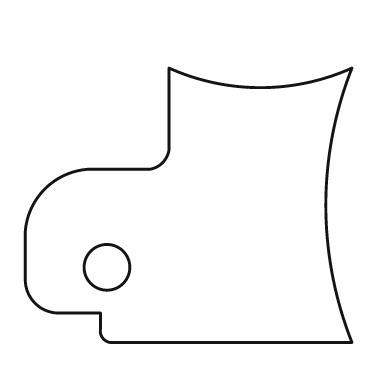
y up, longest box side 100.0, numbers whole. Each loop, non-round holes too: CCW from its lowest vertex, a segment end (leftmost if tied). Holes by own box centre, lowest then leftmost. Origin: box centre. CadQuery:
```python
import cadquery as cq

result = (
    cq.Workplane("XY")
    .moveTo(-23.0, -42.0)
    .lineTo(50.0, -42.0)
    .threePointArc((42.0, 0.0), (50.0, 42.0))
    .threePointArc((22.0, 36.0), (-6.0, 42.0))
    .lineTo(-6.0, 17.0)
    .threePointArc((-8.0, 13.0), (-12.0, 11.0))
    .lineTo(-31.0, 11.0)
    .threePointArc((-44.0, 5.0), (-50.0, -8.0))
    .lineTo(-50.0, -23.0)
    .threePointArc((-47.0, -30.0), (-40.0, -33.0))
    .lineTo(-27.0, -33.0)
    .lineTo(-27.0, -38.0)
    .threePointArc((-26.0, -41.0), (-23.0, -42.0))
    .close()
    .moveTo(-25.0, -19.0)
    .circle(7.0)
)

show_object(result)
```